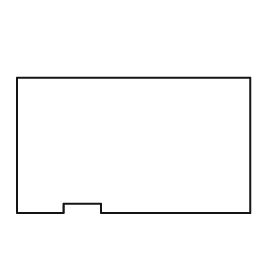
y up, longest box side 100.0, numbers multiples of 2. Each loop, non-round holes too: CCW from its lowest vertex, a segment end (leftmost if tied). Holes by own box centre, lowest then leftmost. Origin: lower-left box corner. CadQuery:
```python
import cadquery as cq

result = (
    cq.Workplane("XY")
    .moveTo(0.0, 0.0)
    .lineTo(20.0, 0.0)
    .lineTo(20.0, 4.0)
    .lineTo(36.0, 4.0)
    .lineTo(36.0, 0.0)
    .lineTo(100.0, 0.0)
    .lineTo(100.0, 58.0)
    .lineTo(0.0, 58.0)
    .close()
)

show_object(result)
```